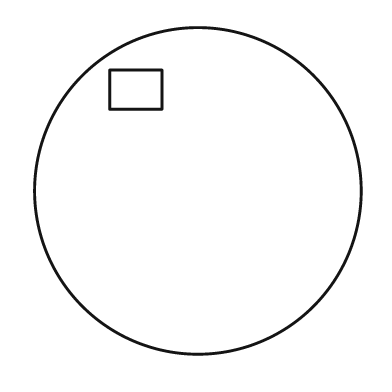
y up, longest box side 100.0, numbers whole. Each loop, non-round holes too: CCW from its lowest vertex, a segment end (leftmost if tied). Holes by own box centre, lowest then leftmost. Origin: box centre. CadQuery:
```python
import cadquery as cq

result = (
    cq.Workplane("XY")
    .moveTo(0.0, 0.0)
    .circle(50.0)
    .moveTo(-27.0, 25.0)
    .lineTo(-11.0, 25.0)
    .lineTo(-11.0, 37.0)
    .lineTo(-27.0, 37.0)
    .close()
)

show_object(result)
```